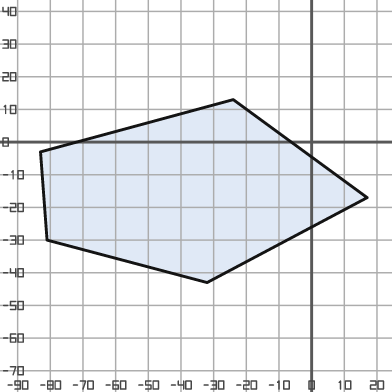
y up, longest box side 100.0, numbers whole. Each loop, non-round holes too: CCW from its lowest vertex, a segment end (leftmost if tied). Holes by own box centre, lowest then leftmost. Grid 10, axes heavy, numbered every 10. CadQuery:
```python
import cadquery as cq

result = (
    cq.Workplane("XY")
    .moveTo(-32.0, -43.0)
    .lineTo(17.0, -17.0)
    .lineTo(-24.0, 13.0)
    .lineTo(-83.0, -3.0)
    .lineTo(-81.0, -30.0)
    .close()
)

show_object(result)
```